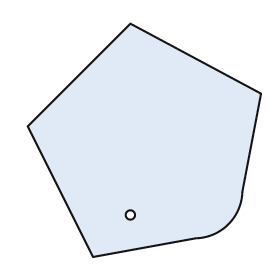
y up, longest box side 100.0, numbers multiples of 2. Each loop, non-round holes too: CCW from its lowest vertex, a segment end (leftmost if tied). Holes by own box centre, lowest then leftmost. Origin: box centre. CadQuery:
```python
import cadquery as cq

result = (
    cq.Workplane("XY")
    .moveTo(-22.0, -50.0)
    .lineTo(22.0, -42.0)
    .threePointArc((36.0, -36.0), (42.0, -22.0))
    .lineTo(50.0, 20.0)
    .lineTo(-6.0, 50.0)
    .lineTo(-50.0, 6.0)
    .close()
    .moveTo(-6.0, -32.0)
    .circle(2.0)
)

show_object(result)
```